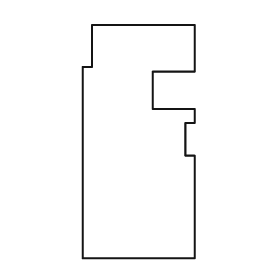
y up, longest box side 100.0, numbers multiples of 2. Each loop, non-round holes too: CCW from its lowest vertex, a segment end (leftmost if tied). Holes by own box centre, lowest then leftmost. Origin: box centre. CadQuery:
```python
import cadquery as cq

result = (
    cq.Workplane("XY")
    .moveTo(-24.0, -50.0)
    .lineTo(24.0, -50.0)
    .lineTo(24.0, -6.0)
    .lineTo(20.0, -6.0)
    .lineTo(20.0, 8.0)
    .lineTo(24.0, 8.0)
    .lineTo(24.0, 14.0)
    .lineTo(6.0, 14.0)
    .lineTo(6.0, 30.0)
    .lineTo(24.0, 30.0)
    .lineTo(24.0, 50.0)
    .lineTo(-20.0, 50.0)
    .lineTo(-20.0, 32.0)
    .lineTo(-24.0, 32.0)
    .close()
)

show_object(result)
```